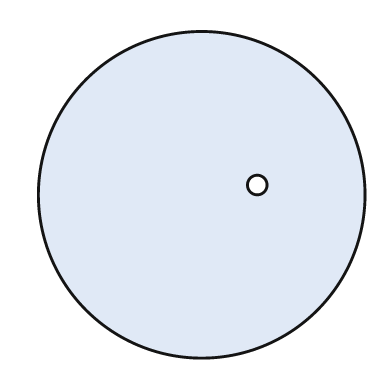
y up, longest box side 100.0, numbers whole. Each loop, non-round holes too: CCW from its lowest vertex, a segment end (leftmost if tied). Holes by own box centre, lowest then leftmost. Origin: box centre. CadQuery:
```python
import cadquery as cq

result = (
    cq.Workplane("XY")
    .moveTo(0.0, 0.0)
    .circle(50.0)
    .moveTo(17.0, 3.0)
    .circle(3.0)
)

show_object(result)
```